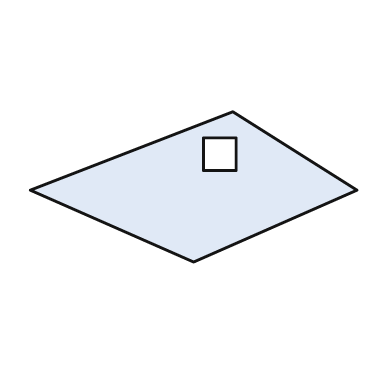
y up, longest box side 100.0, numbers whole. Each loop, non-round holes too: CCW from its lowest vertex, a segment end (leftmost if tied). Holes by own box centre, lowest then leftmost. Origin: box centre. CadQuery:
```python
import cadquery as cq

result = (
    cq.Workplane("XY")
    .moveTo(0.0, -23.0)
    .lineTo(50.0, -1.0)
    .lineTo(12.0, 23.0)
    .lineTo(-50.0, -1.0)
    .close()
    .moveTo(3.0, 5.0)
    .lineTo(13.0, 5.0)
    .lineTo(13.0, 15.0)
    .lineTo(3.0, 15.0)
    .close()
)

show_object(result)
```